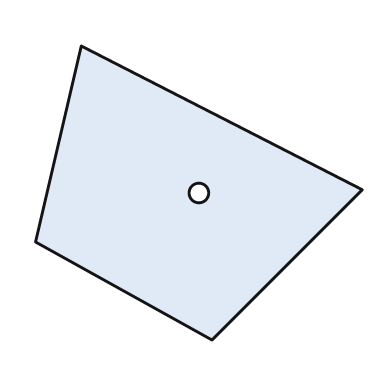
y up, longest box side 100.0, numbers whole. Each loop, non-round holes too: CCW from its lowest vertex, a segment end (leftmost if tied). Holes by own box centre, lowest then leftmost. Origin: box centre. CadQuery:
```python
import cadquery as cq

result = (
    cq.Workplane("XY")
    .moveTo(4.0, -45.0)
    .lineTo(50.0, 1.0)
    .lineTo(-36.0, 45.0)
    .lineTo(-50.0, -15.0)
    .close()
    .moveTo(0.0, 0.0)
    .circle(3.0)
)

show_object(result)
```